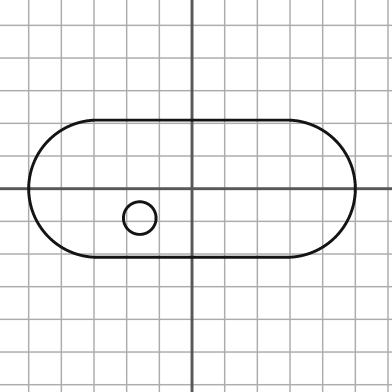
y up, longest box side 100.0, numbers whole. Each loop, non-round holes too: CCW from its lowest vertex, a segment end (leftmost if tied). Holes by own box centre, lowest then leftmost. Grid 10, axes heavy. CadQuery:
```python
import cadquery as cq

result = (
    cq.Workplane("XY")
    .moveTo(-29.0, -21.0)
    .lineTo(29.0, -21.0)
    .threePointArc((50.0, 0.0), (29.0, 21.0))
    .lineTo(-29.0, 21.0)
    .threePointArc((-50.0, 0.0), (-29.0, -21.0))
    .close()
    .moveTo(-16.0, -9.0)
    .circle(5.0)
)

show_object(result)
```